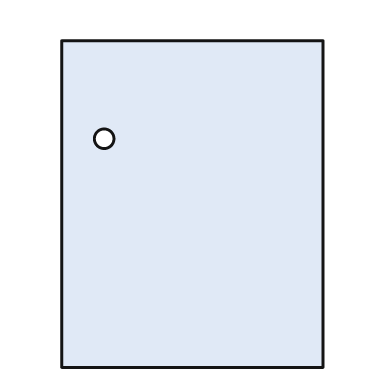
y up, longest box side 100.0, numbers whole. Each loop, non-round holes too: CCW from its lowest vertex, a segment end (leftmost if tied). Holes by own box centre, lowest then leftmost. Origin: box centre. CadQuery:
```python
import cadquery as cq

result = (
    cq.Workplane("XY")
    .moveTo(-40.0, -50.0)
    .lineTo(40.0, -50.0)
    .lineTo(40.0, 50.0)
    .lineTo(-40.0, 50.0)
    .close()
    .moveTo(-27.0, 20.0)
    .circle(3.0)
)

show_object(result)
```